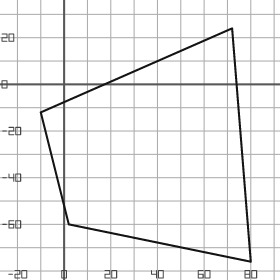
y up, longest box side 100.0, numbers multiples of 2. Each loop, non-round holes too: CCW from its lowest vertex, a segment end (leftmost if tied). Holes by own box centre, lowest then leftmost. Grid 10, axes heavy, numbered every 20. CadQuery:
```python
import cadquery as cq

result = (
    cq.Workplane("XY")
    .moveTo(80.0, -76.0)
    .lineTo(72.0, 24.0)
    .lineTo(-10.0, -12.0)
    .lineTo(2.0, -60.0)
    .close()
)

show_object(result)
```